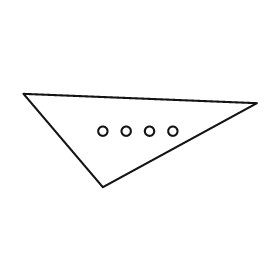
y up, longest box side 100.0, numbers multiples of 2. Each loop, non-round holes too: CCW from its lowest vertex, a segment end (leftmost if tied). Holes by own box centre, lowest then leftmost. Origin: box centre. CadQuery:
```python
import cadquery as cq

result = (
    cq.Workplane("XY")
    .moveTo(-16.0, -20.0)
    .lineTo(50.0, 16.0)
    .lineTo(-50.0, 20.0)
    .close()
    .moveTo(-16.0, 4.0)
    .circle(2.0)
    .moveTo(-6.0, 4.0)
    .circle(2.0)
    .moveTo(4.0, 4.0)
    .circle(2.0)
    .moveTo(14.0, 4.0)
    .circle(2.0)
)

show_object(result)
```